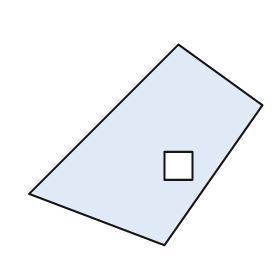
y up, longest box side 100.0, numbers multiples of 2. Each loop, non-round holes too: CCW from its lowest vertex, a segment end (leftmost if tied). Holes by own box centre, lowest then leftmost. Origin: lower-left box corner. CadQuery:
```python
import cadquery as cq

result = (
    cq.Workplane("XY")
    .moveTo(58.0, 0.0)
    .lineTo(100.0, 60.0)
    .lineTo(64.0, 86.0)
    .lineTo(0.0, 22.0)
    .close()
    .moveTo(58.0, 28.0)
    .lineTo(70.0, 28.0)
    .lineTo(70.0, 40.0)
    .lineTo(58.0, 40.0)
    .close()
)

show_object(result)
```